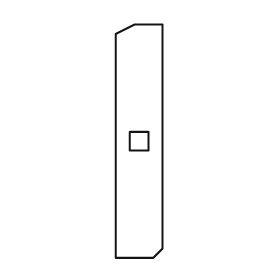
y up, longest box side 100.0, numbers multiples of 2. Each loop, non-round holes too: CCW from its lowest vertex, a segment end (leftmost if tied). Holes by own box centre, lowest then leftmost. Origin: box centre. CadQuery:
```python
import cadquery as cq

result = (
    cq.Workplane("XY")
    .moveTo(-10.0, -50.0)
    .lineTo(6.0, -50.0)
    .lineTo(10.0, -46.0)
    .lineTo(10.0, 50.0)
    .lineTo(-2.0, 50.0)
    .lineTo(-10.0, 46.0)
    .close()
    .moveTo(-4.0, -4.0)
    .lineTo(4.0, -4.0)
    .lineTo(4.0, 4.0)
    .lineTo(-4.0, 4.0)
    .close()
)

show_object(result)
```